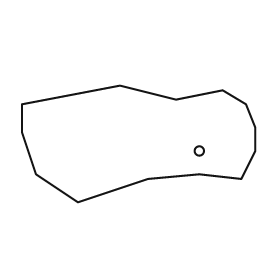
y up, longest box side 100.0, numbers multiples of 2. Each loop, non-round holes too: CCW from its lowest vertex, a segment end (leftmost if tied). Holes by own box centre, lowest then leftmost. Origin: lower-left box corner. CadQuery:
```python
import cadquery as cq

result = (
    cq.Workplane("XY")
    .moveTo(24.0, 0.0)
    .lineTo(54.0, 10.0)
    .lineTo(76.0, 12.0)
    .lineTo(94.0, 10.0)
    .lineTo(100.0, 22.0)
    .lineTo(100.0, 32.0)
    .lineTo(96.0, 42.0)
    .lineTo(86.0, 48.0)
    .lineTo(66.0, 44.0)
    .lineTo(42.0, 50.0)
    .lineTo(0.0, 42.0)
    .lineTo(0.0, 30.0)
    .lineTo(6.0, 12.0)
    .close()
    .moveTo(76.0, 22.0)
    .circle(2.0)
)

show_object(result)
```